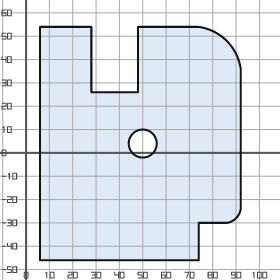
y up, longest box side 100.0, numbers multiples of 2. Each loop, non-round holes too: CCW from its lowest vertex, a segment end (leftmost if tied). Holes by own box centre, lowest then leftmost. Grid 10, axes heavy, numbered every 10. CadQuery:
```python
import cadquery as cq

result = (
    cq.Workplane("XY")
    .moveTo(6.0, -46.0)
    .lineTo(74.0, -46.0)
    .lineTo(74.0, -30.0)
    .lineTo(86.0, -30.0)
    .threePointArc((90.0, -28.0), (92.0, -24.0))
    .lineTo(92.0, 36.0)
    .threePointArc((86.0, 48.0), (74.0, 54.0))
    .lineTo(48.0, 54.0)
    .lineTo(48.0, 26.0)
    .lineTo(28.0, 26.0)
    .lineTo(28.0, 54.0)
    .lineTo(6.0, 54.0)
    .close()
    .moveTo(50.0, 4.0)
    .circle(6.0)
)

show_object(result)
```